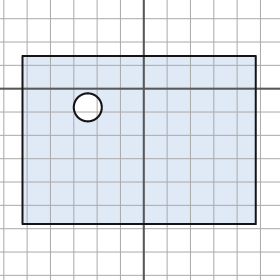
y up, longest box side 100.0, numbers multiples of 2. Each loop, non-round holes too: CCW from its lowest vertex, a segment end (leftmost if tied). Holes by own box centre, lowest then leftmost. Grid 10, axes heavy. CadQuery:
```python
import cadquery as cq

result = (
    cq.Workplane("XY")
    .moveTo(-52.0, -58.0)
    .lineTo(48.0, -58.0)
    .lineTo(48.0, 14.0)
    .lineTo(-52.0, 14.0)
    .close()
    .moveTo(-24.0, -8.0)
    .circle(6.0)
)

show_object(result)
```